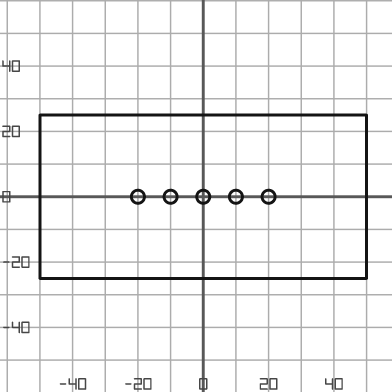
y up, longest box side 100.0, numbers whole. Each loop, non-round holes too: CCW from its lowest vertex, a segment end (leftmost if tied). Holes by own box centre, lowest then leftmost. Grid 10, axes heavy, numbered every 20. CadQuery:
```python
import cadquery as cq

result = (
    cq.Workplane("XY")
    .moveTo(-50.0, -25.0)
    .lineTo(50.0, -25.0)
    .lineTo(50.0, 25.0)
    .lineTo(-50.0, 25.0)
    .close()
    .moveTo(-20.0, 0.0)
    .circle(2.0)
    .moveTo(-10.0, 0.0)
    .circle(2.0)
    .moveTo(0.0, 0.0)
    .circle(2.0)
    .moveTo(10.0, 0.0)
    .circle(2.0)
    .moveTo(20.0, 0.0)
    .circle(2.0)
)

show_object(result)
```